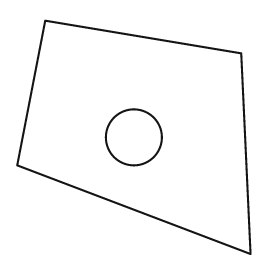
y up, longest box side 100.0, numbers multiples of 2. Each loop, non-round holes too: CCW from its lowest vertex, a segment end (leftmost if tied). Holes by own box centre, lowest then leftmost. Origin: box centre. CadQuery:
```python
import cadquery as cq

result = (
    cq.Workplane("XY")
    .moveTo(50.0, -50.0)
    .lineTo(46.0, 36.0)
    .lineTo(-38.0, 50.0)
    .lineTo(-50.0, -12.0)
    .close()
    .moveTo(0.0, 0.0)
    .circle(12.0)
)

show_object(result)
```